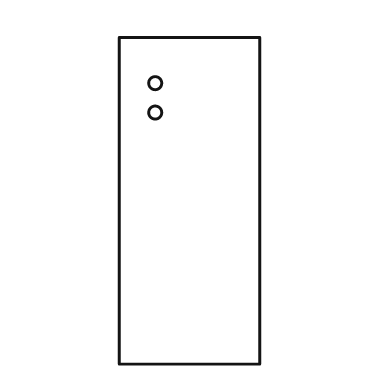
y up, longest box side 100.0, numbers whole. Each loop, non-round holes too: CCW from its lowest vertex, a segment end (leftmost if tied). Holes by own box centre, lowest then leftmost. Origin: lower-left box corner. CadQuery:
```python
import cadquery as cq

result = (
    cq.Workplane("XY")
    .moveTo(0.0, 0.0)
    .lineTo(43.0, 0.0)
    .lineTo(43.0, 100.0)
    .lineTo(0.0, 100.0)
    .close()
    .moveTo(11.0, 77.0)
    .circle(2.0)
    .moveTo(11.0, 86.0)
    .circle(2.0)
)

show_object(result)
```